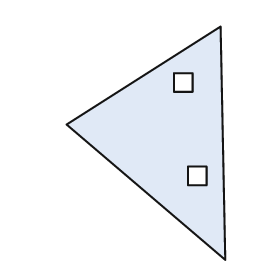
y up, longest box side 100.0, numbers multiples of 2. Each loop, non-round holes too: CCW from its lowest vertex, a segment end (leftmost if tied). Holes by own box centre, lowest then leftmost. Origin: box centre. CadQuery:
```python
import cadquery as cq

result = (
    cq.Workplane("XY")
    .moveTo(34.0, -50.0)
    .lineTo(32.0, 50.0)
    .lineTo(-34.0, 8.0)
    .close()
    .moveTo(18.0, -18.0)
    .lineTo(26.0, -18.0)
    .lineTo(26.0, -10.0)
    .lineTo(18.0, -10.0)
    .close()
    .moveTo(12.0, 22.0)
    .lineTo(20.0, 22.0)
    .lineTo(20.0, 30.0)
    .lineTo(12.0, 30.0)
    .close()
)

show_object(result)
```